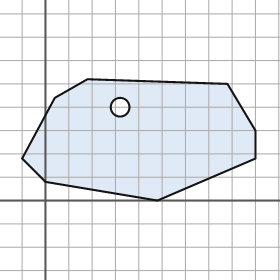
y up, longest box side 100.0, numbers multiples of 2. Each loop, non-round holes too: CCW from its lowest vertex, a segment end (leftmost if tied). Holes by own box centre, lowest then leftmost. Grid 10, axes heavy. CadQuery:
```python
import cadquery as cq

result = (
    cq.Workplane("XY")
    .moveTo(48.0, 0.0)
    .lineTo(90.0, 18.0)
    .lineTo(90.0, 30.0)
    .lineTo(78.0, 50.0)
    .lineTo(18.0, 52.0)
    .lineTo(4.0, 44.0)
    .lineTo(-10.0, 18.0)
    .lineTo(0.0, 8.0)
    .close()
    .moveTo(32.0, 40.0)
    .circle(4.0)
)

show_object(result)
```